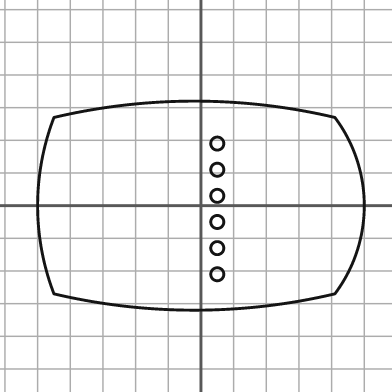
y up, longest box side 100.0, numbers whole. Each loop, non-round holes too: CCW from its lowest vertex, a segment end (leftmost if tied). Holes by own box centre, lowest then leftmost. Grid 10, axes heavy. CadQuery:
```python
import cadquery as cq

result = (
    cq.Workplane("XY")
    .moveTo(-45.0, -27.0)
    .threePointArc((-2.0, -32.0), (41.0, -27.0))
    .threePointArc((50.0, 0.0), (41.0, 27.0))
    .threePointArc((-2.0, 32.0), (-45.0, 27.0))
    .threePointArc((-50.0, 0.0), (-45.0, -27.0))
    .close()
    .moveTo(5.0, -21.0)
    .circle(2.0)
    .moveTo(5.0, -13.0)
    .circle(2.0)
    .moveTo(5.0, -5.0)
    .circle(2.0)
    .moveTo(5.0, 3.0)
    .circle(2.0)
    .moveTo(5.0, 11.0)
    .circle(2.0)
    .moveTo(5.0, 19.0)
    .circle(2.0)
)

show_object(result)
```